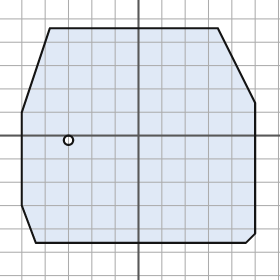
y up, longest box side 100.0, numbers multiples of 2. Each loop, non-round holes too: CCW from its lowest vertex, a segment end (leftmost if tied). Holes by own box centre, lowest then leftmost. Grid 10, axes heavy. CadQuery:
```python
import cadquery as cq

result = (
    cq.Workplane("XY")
    .moveTo(-44.0, -46.0)
    .lineTo(46.0, -46.0)
    .lineTo(50.0, -42.0)
    .lineTo(50.0, 14.0)
    .lineTo(34.0, 46.0)
    .lineTo(-38.0, 46.0)
    .lineTo(-50.0, 10.0)
    .lineTo(-50.0, -30.0)
    .close()
    .moveTo(-30.0, -2.0)
    .circle(2.0)
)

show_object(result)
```